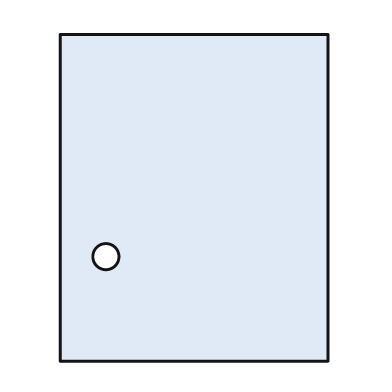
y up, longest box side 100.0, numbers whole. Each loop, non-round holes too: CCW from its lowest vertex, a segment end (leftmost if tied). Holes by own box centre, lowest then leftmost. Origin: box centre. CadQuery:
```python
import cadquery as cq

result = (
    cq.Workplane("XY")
    .moveTo(-41.0, -50.0)
    .lineTo(41.0, -50.0)
    .lineTo(41.0, 50.0)
    .lineTo(-41.0, 50.0)
    .close()
    .moveTo(-27.0, -18.0)
    .circle(4.0)
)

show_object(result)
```